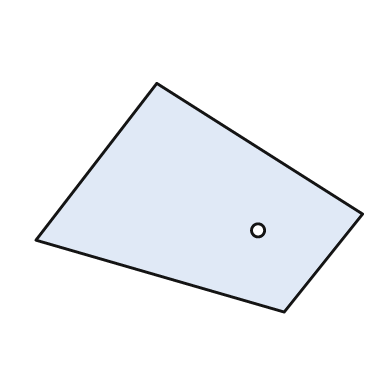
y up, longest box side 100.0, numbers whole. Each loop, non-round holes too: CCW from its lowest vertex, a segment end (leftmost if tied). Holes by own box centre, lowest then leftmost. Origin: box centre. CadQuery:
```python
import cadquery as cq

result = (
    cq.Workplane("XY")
    .moveTo(26.0, -35.0)
    .lineTo(50.0, -5.0)
    .lineTo(-13.0, 35.0)
    .lineTo(-50.0, -13.0)
    .close()
    .moveTo(18.0, -10.0)
    .circle(2.0)
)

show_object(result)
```